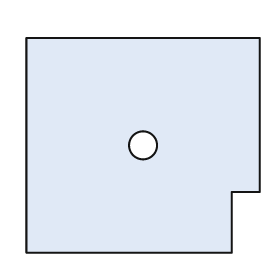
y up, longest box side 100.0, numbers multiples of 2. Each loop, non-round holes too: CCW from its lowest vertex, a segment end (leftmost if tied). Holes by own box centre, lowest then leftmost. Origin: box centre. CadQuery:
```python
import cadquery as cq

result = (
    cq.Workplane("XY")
    .moveTo(-50.0, -46.0)
    .lineTo(38.0, -46.0)
    .lineTo(38.0, -20.0)
    .lineTo(50.0, -20.0)
    .lineTo(50.0, 46.0)
    .lineTo(-50.0, 46.0)
    .close()
    .moveTo(0.0, 0.0)
    .circle(6.0)
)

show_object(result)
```